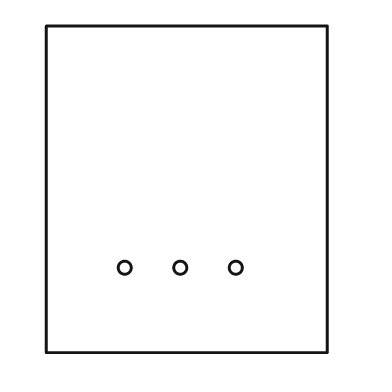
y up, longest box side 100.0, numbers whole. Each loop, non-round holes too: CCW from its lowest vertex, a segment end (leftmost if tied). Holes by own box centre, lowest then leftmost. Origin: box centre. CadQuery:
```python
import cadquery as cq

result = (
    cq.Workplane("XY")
    .moveTo(-43.0, -50.0)
    .lineTo(43.0, -50.0)
    .lineTo(43.0, 50.0)
    .lineTo(-43.0, 50.0)
    .close()
    .moveTo(-19.0, -24.0)
    .circle(2.0)
    .moveTo(-2.0, -24.0)
    .circle(2.0)
    .moveTo(15.0, -24.0)
    .circle(2.0)
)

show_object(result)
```